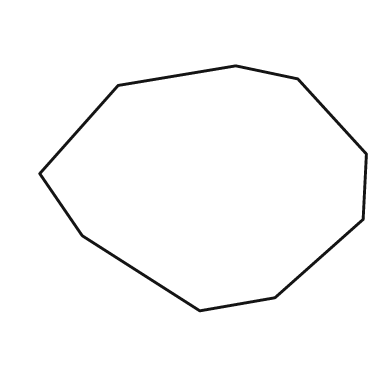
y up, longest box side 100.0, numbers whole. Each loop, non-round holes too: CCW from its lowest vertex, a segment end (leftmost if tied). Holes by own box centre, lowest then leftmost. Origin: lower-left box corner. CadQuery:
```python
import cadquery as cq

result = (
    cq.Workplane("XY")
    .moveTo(49.0, 0.0)
    .lineTo(72.0, 4.0)
    .lineTo(99.0, 28.0)
    .lineTo(100.0, 48.0)
    .lineTo(79.0, 71.0)
    .lineTo(60.0, 75.0)
    .lineTo(24.0, 69.0)
    .lineTo(0.0, 42.0)
    .lineTo(13.0, 23.0)
    .close()
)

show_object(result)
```